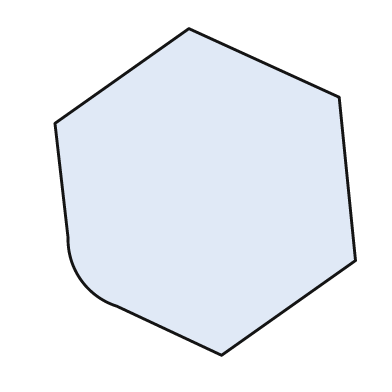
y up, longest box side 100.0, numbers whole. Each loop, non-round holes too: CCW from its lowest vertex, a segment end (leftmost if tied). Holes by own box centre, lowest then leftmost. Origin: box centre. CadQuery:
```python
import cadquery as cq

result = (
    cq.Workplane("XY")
    .moveTo(5.0, -50.0)
    .lineTo(46.0, -21.0)
    .lineTo(41.0, 29.0)
    .lineTo(-5.0, 50.0)
    .lineTo(-46.0, 21.0)
    .lineTo(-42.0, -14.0)
    .threePointArc((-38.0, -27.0), (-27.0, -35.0))
    .close()
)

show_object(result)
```